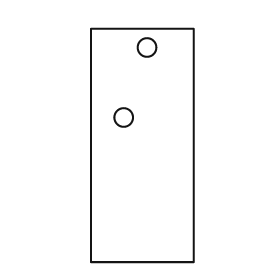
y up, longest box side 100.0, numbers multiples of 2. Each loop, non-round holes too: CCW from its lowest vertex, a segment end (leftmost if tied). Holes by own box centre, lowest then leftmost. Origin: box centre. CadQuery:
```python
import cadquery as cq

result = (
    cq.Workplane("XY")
    .moveTo(-22.0, -50.0)
    .lineTo(22.0, -50.0)
    .lineTo(22.0, 50.0)
    .lineTo(-22.0, 50.0)
    .close()
    .moveTo(-8.0, 12.0)
    .circle(4.0)
    .moveTo(2.0, 42.0)
    .circle(4.0)
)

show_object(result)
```